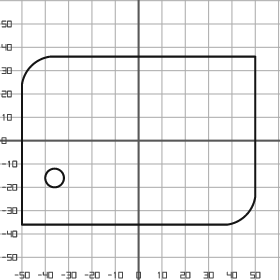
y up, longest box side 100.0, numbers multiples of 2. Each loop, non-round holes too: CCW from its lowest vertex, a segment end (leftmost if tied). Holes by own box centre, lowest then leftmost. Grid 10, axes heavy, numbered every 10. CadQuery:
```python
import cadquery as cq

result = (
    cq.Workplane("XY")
    .moveTo(-50.0, -36.0)
    .lineTo(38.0, -36.0)
    .threePointArc((46.0, -32.0), (50.0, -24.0))
    .lineTo(50.0, 36.0)
    .lineTo(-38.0, 36.0)
    .threePointArc((-46.0, 32.0), (-50.0, 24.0))
    .close()
    .moveTo(-36.0, -16.0)
    .circle(4.0)
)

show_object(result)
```